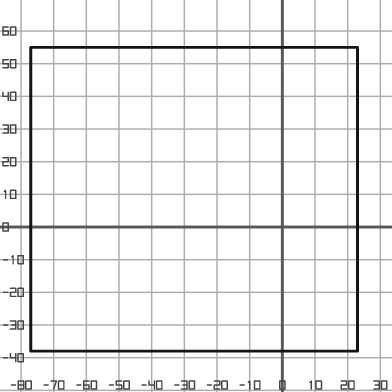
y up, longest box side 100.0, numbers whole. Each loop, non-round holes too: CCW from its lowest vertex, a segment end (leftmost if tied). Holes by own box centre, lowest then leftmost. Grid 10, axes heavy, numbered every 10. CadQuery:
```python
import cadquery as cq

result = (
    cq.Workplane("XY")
    .moveTo(-77.0, -38.0)
    .lineTo(23.0, -38.0)
    .lineTo(23.0, 55.0)
    .lineTo(-77.0, 55.0)
    .close()
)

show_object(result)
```